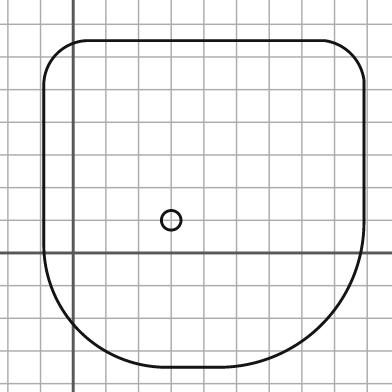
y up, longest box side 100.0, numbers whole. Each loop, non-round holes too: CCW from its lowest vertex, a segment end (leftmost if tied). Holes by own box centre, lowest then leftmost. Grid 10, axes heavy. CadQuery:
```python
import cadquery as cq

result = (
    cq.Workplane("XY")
    .moveTo(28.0, -35.0)
    .lineTo(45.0, -35.0)
    .threePointArc((76.0, -22.0), (89.0, 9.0))
    .lineTo(89.0, 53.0)
    .threePointArc((85.0, 61.0), (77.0, 65.0))
    .lineTo(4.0, 65.0)
    .threePointArc((-5.0, 61.0), (-9.0, 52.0))
    .lineTo(-9.0, 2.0)
    .threePointArc((2.0, -24.0), (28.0, -35.0))
    .close()
    .moveTo(30.0, 10.0)
    .circle(3.0)
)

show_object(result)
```